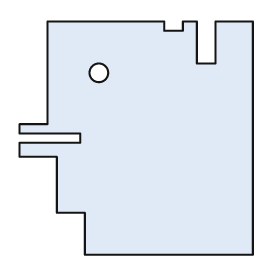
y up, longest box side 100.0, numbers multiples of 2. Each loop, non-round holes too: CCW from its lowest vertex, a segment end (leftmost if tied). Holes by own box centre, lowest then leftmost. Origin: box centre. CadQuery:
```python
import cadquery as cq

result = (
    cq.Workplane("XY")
    .moveTo(-22.0, -50.0)
    .lineTo(50.0, -50.0)
    .lineTo(50.0, 50.0)
    .lineTo(34.0, 50.0)
    .lineTo(34.0, 32.0)
    .lineTo(26.0, 32.0)
    .lineTo(26.0, 50.0)
    .lineTo(20.0, 50.0)
    .lineTo(20.0, 46.0)
    .lineTo(12.0, 46.0)
    .lineTo(12.0, 50.0)
    .lineTo(-38.0, 50.0)
    .lineTo(-38.0, 6.0)
    .lineTo(-50.0, 6.0)
    .lineTo(-50.0, 2.0)
    .lineTo(-24.0, 2.0)
    .lineTo(-24.0, -2.0)
    .lineTo(-50.0, -2.0)
    .lineTo(-50.0, -8.0)
    .lineTo(-34.0, -8.0)
    .lineTo(-34.0, -32.0)
    .lineTo(-22.0, -32.0)
    .close()
    .moveTo(-16.0, 28.0)
    .circle(4.0)
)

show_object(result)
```